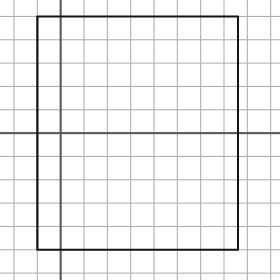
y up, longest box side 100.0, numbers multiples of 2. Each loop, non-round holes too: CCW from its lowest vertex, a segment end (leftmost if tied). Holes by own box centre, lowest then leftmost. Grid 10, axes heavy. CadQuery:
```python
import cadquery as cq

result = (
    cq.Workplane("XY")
    .moveTo(-10.0, -50.0)
    .lineTo(76.0, -50.0)
    .lineTo(76.0, 50.0)
    .lineTo(-10.0, 50.0)
    .close()
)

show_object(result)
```